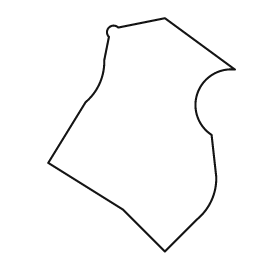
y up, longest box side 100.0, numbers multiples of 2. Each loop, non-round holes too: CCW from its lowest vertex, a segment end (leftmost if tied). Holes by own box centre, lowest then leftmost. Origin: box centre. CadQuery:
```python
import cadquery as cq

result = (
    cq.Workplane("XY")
    .moveTo(10.0, -50.0)
    .lineTo(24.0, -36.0)
    .threePointArc((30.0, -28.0), (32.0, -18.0))
    .lineTo(30.0, 0.0)
    .threePointArc((24.0, 18.0), (40.0, 28.0))
    .lineTo(10.0, 50.0)
    .lineTo(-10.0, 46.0)
    .threePointArc((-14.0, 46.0), (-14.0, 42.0))
    .lineTo(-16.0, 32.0)
    .threePointArc((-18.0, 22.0), (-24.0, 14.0))
    .lineTo(-40.0, -12.0)
    .lineTo(-8.0, -32.0)
    .close()
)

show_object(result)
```